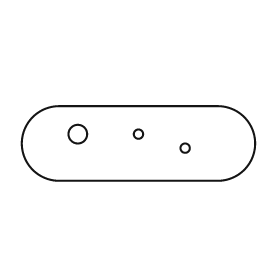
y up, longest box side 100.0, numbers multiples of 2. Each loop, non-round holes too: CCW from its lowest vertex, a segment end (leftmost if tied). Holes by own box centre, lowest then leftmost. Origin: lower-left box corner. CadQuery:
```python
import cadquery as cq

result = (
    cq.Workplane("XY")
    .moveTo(16.0, 0.0)
    .lineTo(84.0, 0.0)
    .threePointArc((100.0, 16.0), (84.0, 32.0))
    .lineTo(16.0, 32.0)
    .threePointArc((0.0, 16.0), (16.0, 0.0))
    .close()
    .moveTo(70.0, 14.0)
    .circle(2.0)
    .moveTo(24.0, 20.0)
    .circle(4.0)
    .moveTo(50.0, 20.0)
    .circle(2.0)
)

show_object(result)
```